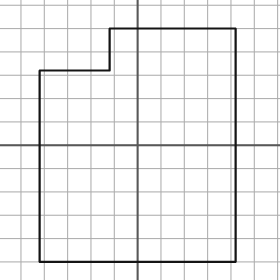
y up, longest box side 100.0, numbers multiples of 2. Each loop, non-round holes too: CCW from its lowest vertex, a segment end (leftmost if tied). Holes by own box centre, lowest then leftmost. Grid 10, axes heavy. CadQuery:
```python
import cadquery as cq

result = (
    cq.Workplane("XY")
    .moveTo(-42.0, -50.0)
    .lineTo(42.0, -50.0)
    .lineTo(42.0, 50.0)
    .lineTo(-12.0, 50.0)
    .lineTo(-12.0, 32.0)
    .lineTo(-42.0, 32.0)
    .close()
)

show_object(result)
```